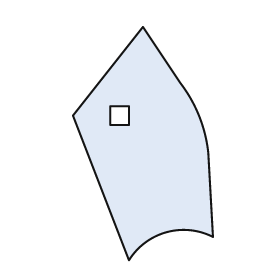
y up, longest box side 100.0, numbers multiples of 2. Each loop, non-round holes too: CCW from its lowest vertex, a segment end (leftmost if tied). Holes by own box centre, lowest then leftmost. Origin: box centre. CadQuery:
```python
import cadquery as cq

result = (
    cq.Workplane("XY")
    .moveTo(-6.0, -50.0)
    .threePointArc((10.0, -38.0), (30.0, -40.0))
    .lineTo(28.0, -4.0)
    .threePointArc((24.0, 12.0), (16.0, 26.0))
    .lineTo(0.0, 50.0)
    .lineTo(-30.0, 12.0)
    .close()
    .moveTo(-14.0, 8.0)
    .lineTo(-6.0, 8.0)
    .lineTo(-6.0, 16.0)
    .lineTo(-14.0, 16.0)
    .close()
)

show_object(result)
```